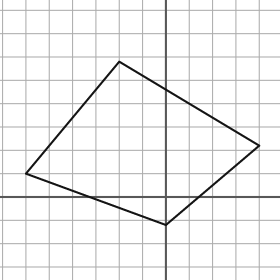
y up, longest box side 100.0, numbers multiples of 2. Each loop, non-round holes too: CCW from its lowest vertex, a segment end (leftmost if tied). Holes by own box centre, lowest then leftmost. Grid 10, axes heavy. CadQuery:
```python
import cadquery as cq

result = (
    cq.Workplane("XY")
    .moveTo(0.0, -12.0)
    .lineTo(40.0, 22.0)
    .lineTo(-20.0, 58.0)
    .lineTo(-60.0, 10.0)
    .close()
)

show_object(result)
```